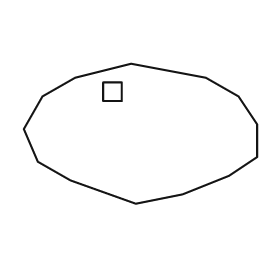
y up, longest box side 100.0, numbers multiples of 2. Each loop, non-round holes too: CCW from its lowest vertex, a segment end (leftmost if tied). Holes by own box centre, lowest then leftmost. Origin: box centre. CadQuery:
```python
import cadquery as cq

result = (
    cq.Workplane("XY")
    .moveTo(-2.0, -30.0)
    .lineTo(18.0, -26.0)
    .lineTo(38.0, -18.0)
    .lineTo(50.0, -10.0)
    .lineTo(50.0, 4.0)
    .lineTo(42.0, 16.0)
    .lineTo(28.0, 24.0)
    .lineTo(-4.0, 30.0)
    .lineTo(-28.0, 24.0)
    .lineTo(-42.0, 16.0)
    .lineTo(-50.0, 2.0)
    .lineTo(-44.0, -12.0)
    .lineTo(-30.0, -20.0)
    .close()
    .moveTo(-16.0, 14.0)
    .lineTo(-8.0, 14.0)
    .lineTo(-8.0, 22.0)
    .lineTo(-16.0, 22.0)
    .close()
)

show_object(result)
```